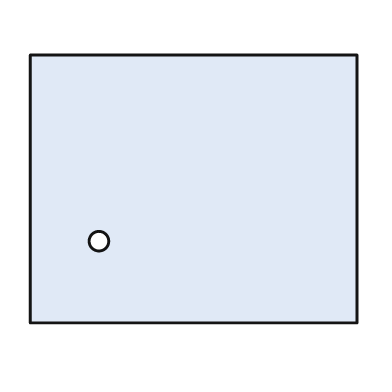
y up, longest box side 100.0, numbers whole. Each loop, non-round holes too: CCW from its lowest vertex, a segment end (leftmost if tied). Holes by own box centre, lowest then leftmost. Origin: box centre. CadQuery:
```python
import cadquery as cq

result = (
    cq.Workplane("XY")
    .moveTo(-50.0, -41.0)
    .lineTo(50.0, -41.0)
    .lineTo(50.0, 41.0)
    .lineTo(-50.0, 41.0)
    .close()
    .moveTo(-29.0, -16.0)
    .circle(3.0)
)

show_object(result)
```